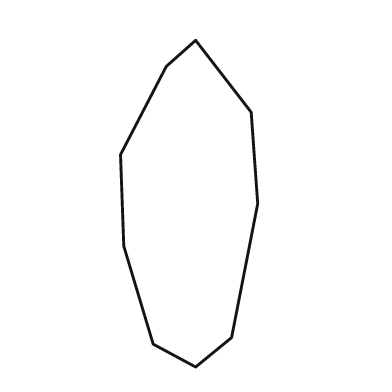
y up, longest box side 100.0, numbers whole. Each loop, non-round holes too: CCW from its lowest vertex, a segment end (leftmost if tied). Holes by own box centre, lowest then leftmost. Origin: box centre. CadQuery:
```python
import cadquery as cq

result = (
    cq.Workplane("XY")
    .moveTo(2.0, -50.0)
    .lineTo(13.0, -41.0)
    .lineTo(21.0, 0.0)
    .lineTo(19.0, 28.0)
    .lineTo(2.0, 50.0)
    .lineTo(-7.0, 42.0)
    .lineTo(-21.0, 15.0)
    .lineTo(-20.0, -13.0)
    .lineTo(-11.0, -43.0)
    .close()
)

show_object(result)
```